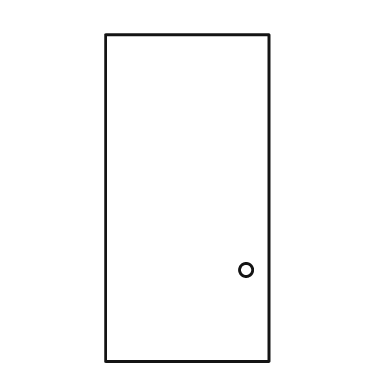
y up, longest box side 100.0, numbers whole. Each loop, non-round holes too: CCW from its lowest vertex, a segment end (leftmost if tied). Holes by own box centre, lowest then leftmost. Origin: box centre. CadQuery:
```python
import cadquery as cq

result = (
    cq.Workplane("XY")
    .moveTo(-25.0, -50.0)
    .lineTo(25.0, -50.0)
    .lineTo(25.0, 50.0)
    .lineTo(-25.0, 50.0)
    .close()
    .moveTo(18.0, -22.0)
    .circle(2.0)
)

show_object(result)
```